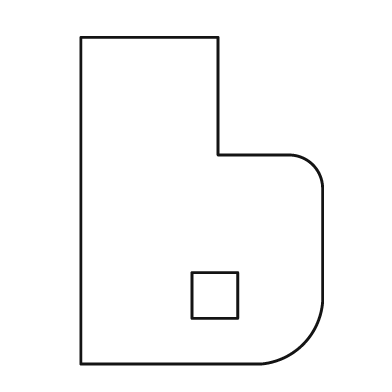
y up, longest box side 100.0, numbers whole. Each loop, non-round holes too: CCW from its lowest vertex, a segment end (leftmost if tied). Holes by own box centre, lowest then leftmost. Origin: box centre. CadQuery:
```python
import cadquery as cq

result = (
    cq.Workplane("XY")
    .moveTo(-37.0, -50.0)
    .lineTo(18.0, -50.0)
    .threePointArc((31.0, -44.0), (37.0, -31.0))
    .lineTo(37.0, 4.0)
    .threePointArc((34.0, 11.0), (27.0, 14.0))
    .lineTo(5.0, 14.0)
    .lineTo(5.0, 50.0)
    .lineTo(-37.0, 50.0)
    .close()
    .moveTo(-3.0, -36.0)
    .lineTo(11.0, -36.0)
    .lineTo(11.0, -22.0)
    .lineTo(-3.0, -22.0)
    .close()
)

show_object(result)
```